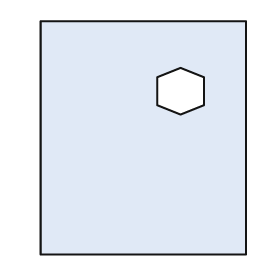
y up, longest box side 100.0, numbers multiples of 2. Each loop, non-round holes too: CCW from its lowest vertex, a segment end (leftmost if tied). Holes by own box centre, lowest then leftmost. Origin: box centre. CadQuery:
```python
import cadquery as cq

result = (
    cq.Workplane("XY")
    .moveTo(-44.0, -50.0)
    .lineTo(44.0, -50.0)
    .lineTo(44.0, 50.0)
    .lineTo(-44.0, 50.0)
    .close()
    .moveTo(16.0, 10.0)
    .lineTo(26.0, 14.0)
    .lineTo(26.0, 26.0)
    .lineTo(16.0, 30.0)
    .lineTo(6.0, 26.0)
    .lineTo(6.0, 14.0)
    .close()
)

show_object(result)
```